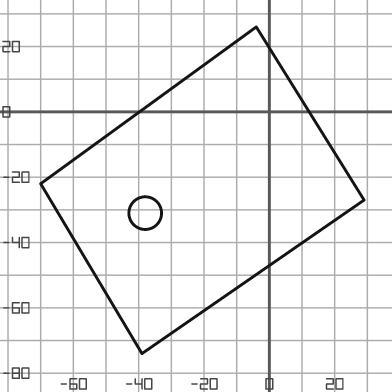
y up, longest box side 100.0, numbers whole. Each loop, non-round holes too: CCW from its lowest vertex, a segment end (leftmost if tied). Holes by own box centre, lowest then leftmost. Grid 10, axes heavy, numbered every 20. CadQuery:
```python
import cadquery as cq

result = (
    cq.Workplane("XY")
    .moveTo(-39.0, -74.0)
    .lineTo(29.0, -27.0)
    .lineTo(-4.0, 26.0)
    .lineTo(-70.0, -22.0)
    .close()
    .moveTo(-38.0, -31.0)
    .circle(5.0)
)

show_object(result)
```